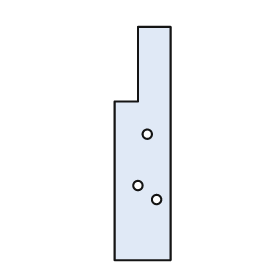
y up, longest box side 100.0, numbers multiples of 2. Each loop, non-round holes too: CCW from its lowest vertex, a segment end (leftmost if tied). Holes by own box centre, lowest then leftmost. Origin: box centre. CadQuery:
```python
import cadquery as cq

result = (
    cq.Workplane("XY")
    .moveTo(-12.0, -50.0)
    .lineTo(12.0, -50.0)
    .lineTo(12.0, 50.0)
    .lineTo(-2.0, 50.0)
    .lineTo(-2.0, 18.0)
    .lineTo(-12.0, 18.0)
    .close()
    .moveTo(6.0, -24.0)
    .circle(2.0)
    .moveTo(-2.0, -18.0)
    .circle(2.0)
    .moveTo(2.0, 4.0)
    .circle(2.0)
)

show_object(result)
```